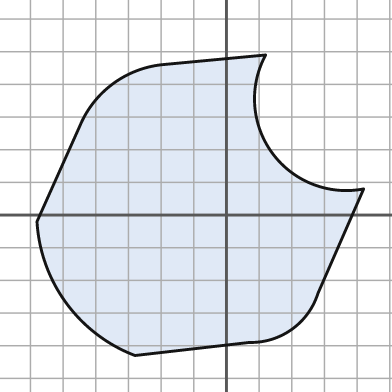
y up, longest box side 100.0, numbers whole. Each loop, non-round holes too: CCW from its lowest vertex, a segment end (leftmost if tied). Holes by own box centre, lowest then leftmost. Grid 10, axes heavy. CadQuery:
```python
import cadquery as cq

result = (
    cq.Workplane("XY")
    .moveTo(-28.0, -43.0)
    .lineTo(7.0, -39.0)
    .threePointArc((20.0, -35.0), (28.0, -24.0))
    .lineTo(42.0, 8.0)
    .threePointArc((14.0, 19.0), (12.0, 49.0))
    .lineTo(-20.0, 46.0)
    .threePointArc((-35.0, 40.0), (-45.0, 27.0))
    .lineTo(-58.0, -2.0)
    .threePointArc((-49.0, -27.0), (-28.0, -43.0))
    .close()
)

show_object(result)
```